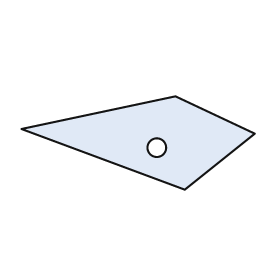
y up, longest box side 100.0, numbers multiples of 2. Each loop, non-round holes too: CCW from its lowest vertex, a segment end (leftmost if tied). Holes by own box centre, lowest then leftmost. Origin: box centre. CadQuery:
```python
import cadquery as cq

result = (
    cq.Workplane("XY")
    .moveTo(20.0, -20.0)
    .lineTo(50.0, 4.0)
    .lineTo(16.0, 20.0)
    .lineTo(-50.0, 6.0)
    .close()
    .moveTo(8.0, -2.0)
    .circle(4.0)
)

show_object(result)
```